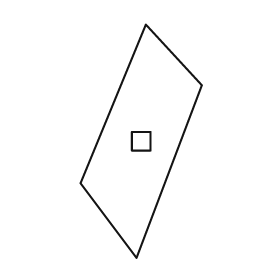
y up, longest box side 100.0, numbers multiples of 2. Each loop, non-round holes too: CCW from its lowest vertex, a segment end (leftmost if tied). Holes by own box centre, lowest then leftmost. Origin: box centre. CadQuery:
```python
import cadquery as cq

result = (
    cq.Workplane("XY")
    .moveTo(-2.0, -50.0)
    .lineTo(26.0, 24.0)
    .lineTo(2.0, 50.0)
    .lineTo(-26.0, -18.0)
    .close()
    .moveTo(-4.0, -4.0)
    .lineTo(4.0, -4.0)
    .lineTo(4.0, 4.0)
    .lineTo(-4.0, 4.0)
    .close()
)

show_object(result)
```